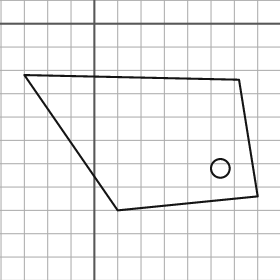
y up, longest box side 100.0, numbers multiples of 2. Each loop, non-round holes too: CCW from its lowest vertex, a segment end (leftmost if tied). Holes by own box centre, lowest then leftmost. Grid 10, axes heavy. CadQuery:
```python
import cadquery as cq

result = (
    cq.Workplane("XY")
    .moveTo(10.0, -80.0)
    .lineTo(70.0, -74.0)
    .lineTo(62.0, -24.0)
    .lineTo(-30.0, -22.0)
    .close()
    .moveTo(54.0, -62.0)
    .circle(4.0)
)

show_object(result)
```